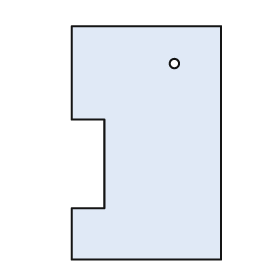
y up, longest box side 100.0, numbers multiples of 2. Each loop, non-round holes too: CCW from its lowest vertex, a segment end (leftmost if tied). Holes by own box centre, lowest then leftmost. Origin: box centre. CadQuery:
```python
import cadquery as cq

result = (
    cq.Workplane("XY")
    .moveTo(-32.0, -50.0)
    .lineTo(32.0, -50.0)
    .lineTo(32.0, 50.0)
    .lineTo(-32.0, 50.0)
    .lineTo(-32.0, 10.0)
    .lineTo(-18.0, 10.0)
    .lineTo(-18.0, -28.0)
    .lineTo(-32.0, -28.0)
    .close()
    .moveTo(12.0, 34.0)
    .circle(2.0)
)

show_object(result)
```